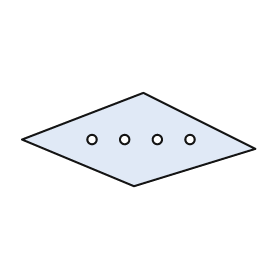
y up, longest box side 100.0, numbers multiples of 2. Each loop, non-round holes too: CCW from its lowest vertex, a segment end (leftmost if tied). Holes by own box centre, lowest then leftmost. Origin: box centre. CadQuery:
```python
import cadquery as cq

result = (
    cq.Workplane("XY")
    .moveTo(-2.0, -20.0)
    .lineTo(50.0, -4.0)
    .lineTo(2.0, 20.0)
    .lineTo(-50.0, 0.0)
    .close()
    .moveTo(-20.0, 0.0)
    .circle(2.0)
    .moveTo(-6.0, 0.0)
    .circle(2.0)
    .moveTo(8.0, 0.0)
    .circle(2.0)
    .moveTo(22.0, 0.0)
    .circle(2.0)
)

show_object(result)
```